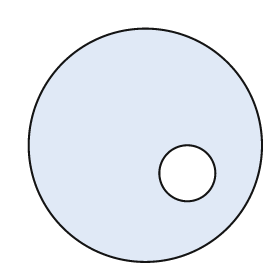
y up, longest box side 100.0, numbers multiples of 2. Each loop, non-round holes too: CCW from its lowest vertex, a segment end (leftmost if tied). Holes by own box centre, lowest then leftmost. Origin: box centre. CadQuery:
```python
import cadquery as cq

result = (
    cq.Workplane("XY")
    .moveTo(0.0, 0.0)
    .circle(50.0)
    .moveTo(18.0, -12.0)
    .circle(12.0)
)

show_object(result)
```